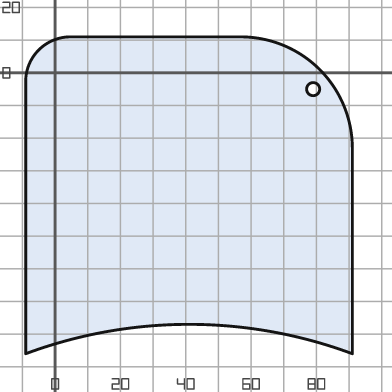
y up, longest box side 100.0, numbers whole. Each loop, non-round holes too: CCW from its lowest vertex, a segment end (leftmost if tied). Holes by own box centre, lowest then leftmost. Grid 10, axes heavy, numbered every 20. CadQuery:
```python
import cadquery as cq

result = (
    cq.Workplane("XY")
    .moveTo(-9.0, -86.0)
    .threePointArc((41.0, -77.0), (91.0, -86.0))
    .lineTo(91.0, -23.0)
    .threePointArc((81.0, 1.0), (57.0, 11.0))
    .lineTo(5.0, 11.0)
    .threePointArc((-5.0, 7.0), (-9.0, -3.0))
    .close()
    .moveTo(79.0, -5.0)
    .circle(2.0)
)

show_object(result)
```